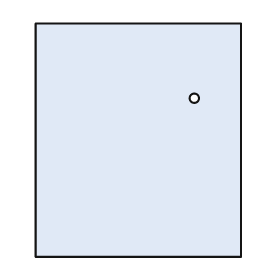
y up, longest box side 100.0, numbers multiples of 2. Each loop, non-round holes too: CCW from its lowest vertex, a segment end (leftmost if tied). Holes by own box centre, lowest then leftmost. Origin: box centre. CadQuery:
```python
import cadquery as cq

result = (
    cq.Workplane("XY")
    .moveTo(-44.0, -50.0)
    .lineTo(44.0, -50.0)
    .lineTo(44.0, 50.0)
    .lineTo(-44.0, 50.0)
    .close()
    .moveTo(24.0, 18.0)
    .circle(2.0)
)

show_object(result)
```